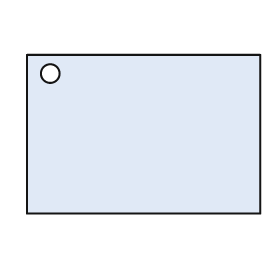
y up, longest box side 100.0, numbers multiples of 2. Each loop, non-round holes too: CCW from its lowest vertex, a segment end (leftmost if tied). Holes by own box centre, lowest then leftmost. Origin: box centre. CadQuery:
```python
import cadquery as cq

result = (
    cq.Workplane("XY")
    .moveTo(-50.0, -34.0)
    .lineTo(50.0, -34.0)
    .lineTo(50.0, 34.0)
    .lineTo(-50.0, 34.0)
    .close()
    .moveTo(-40.0, 26.0)
    .circle(4.0)
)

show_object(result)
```